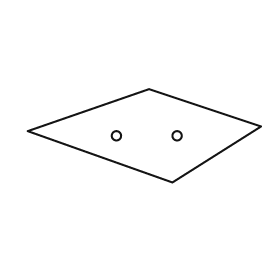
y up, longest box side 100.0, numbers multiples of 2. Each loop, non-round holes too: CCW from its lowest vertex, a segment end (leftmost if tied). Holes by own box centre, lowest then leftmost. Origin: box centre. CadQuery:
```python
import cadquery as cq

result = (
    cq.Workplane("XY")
    .moveTo(12.0, -20.0)
    .lineTo(50.0, 4.0)
    .lineTo(2.0, 20.0)
    .lineTo(-50.0, 2.0)
    .close()
    .moveTo(-12.0, 0.0)
    .circle(2.0)
    .moveTo(14.0, 0.0)
    .circle(2.0)
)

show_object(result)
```